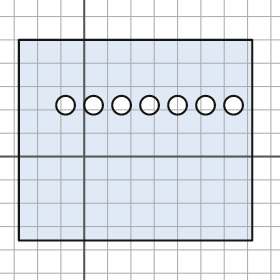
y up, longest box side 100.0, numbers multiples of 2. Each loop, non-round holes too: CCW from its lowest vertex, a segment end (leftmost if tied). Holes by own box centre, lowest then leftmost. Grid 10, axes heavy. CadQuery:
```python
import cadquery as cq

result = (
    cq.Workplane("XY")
    .moveTo(-28.0, -36.0)
    .lineTo(72.0, -36.0)
    .lineTo(72.0, 50.0)
    .lineTo(-28.0, 50.0)
    .close()
    .moveTo(-8.0, 22.0)
    .circle(4.0)
    .moveTo(4.0, 22.0)
    .circle(4.0)
    .moveTo(16.0, 22.0)
    .circle(4.0)
    .moveTo(28.0, 22.0)
    .circle(4.0)
    .moveTo(40.0, 22.0)
    .circle(4.0)
    .moveTo(52.0, 22.0)
    .circle(4.0)
    .moveTo(64.0, 22.0)
    .circle(4.0)
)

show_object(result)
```